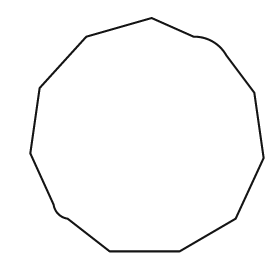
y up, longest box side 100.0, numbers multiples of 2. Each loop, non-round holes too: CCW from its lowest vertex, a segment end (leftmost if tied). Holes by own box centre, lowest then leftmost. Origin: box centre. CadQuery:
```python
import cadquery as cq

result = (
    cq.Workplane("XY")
    .moveTo(-16.0, -50.0)
    .lineTo(14.0, -50.0)
    .lineTo(38.0, -36.0)
    .lineTo(50.0, -10.0)
    .lineTo(46.0, 18.0)
    .lineTo(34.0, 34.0)
    .threePointArc((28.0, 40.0), (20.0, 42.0))
    .lineTo(2.0, 50.0)
    .lineTo(-26.0, 42.0)
    .lineTo(-46.0, 20.0)
    .lineTo(-50.0, -8.0)
    .lineTo(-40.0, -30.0)
    .threePointArc((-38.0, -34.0), (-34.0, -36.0))
    .close()
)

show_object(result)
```